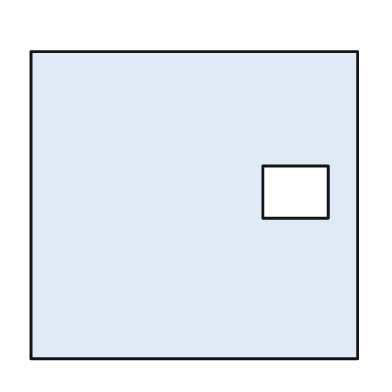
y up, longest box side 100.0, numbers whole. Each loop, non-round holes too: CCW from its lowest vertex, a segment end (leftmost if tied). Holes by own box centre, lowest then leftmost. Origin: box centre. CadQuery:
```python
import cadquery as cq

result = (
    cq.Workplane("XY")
    .moveTo(-50.0, -47.0)
    .lineTo(50.0, -47.0)
    .lineTo(50.0, 47.0)
    .lineTo(-50.0, 47.0)
    .close()
    .moveTo(21.0, -4.0)
    .lineTo(41.0, -4.0)
    .lineTo(41.0, 12.0)
    .lineTo(21.0, 12.0)
    .close()
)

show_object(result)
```